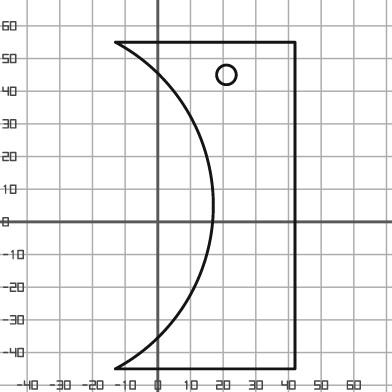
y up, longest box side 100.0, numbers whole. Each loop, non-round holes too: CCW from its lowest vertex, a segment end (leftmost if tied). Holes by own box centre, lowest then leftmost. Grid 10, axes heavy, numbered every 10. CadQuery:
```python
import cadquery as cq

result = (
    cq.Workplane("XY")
    .moveTo(-13.0, -45.0)
    .lineTo(42.0, -45.0)
    .lineTo(42.0, 55.0)
    .lineTo(-13.0, 55.0)
    .threePointArc((17.0, 5.0), (-13.0, -45.0))
    .close()
    .moveTo(21.0, 45.0)
    .circle(3.0)
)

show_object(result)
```